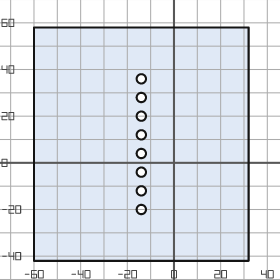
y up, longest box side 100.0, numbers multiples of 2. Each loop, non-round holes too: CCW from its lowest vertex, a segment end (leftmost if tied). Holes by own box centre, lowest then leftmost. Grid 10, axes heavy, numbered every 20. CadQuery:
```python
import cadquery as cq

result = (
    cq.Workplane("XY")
    .moveTo(-60.0, -42.0)
    .lineTo(32.0, -42.0)
    .lineTo(32.0, 58.0)
    .lineTo(-60.0, 58.0)
    .close()
    .moveTo(-14.0, -20.0)
    .circle(2.0)
    .moveTo(-14.0, -12.0)
    .circle(2.0)
    .moveTo(-14.0, -4.0)
    .circle(2.0)
    .moveTo(-14.0, 4.0)
    .circle(2.0)
    .moveTo(-14.0, 12.0)
    .circle(2.0)
    .moveTo(-14.0, 20.0)
    .circle(2.0)
    .moveTo(-14.0, 28.0)
    .circle(2.0)
    .moveTo(-14.0, 36.0)
    .circle(2.0)
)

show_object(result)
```